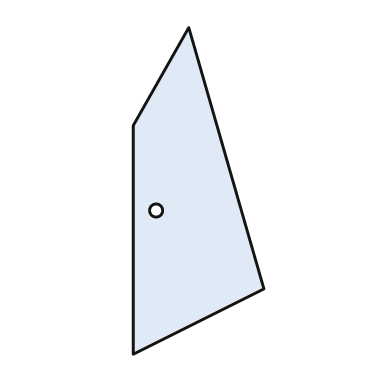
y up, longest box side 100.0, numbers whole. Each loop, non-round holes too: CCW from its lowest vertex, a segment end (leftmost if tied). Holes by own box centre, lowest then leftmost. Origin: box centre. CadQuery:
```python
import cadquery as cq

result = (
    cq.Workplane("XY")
    .moveTo(-20.0, -50.0)
    .lineTo(20.0, -30.0)
    .lineTo(-3.0, 50.0)
    .lineTo(-20.0, 20.0)
    .close()
    .moveTo(-13.0, -6.0)
    .circle(2.0)
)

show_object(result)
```